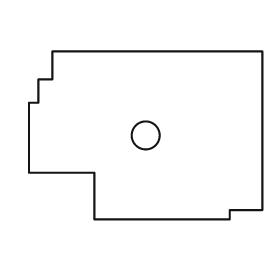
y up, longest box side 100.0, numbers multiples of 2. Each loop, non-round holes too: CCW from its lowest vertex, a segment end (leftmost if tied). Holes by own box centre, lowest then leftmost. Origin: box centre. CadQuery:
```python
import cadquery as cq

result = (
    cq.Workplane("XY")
    .moveTo(-22.0, -36.0)
    .lineTo(36.0, -36.0)
    .lineTo(36.0, -32.0)
    .lineTo(50.0, -32.0)
    .lineTo(50.0, 36.0)
    .lineTo(-40.0, 36.0)
    .lineTo(-40.0, 24.0)
    .lineTo(-46.0, 24.0)
    .lineTo(-46.0, 14.0)
    .lineTo(-50.0, 14.0)
    .lineTo(-50.0, -16.0)
    .lineTo(-22.0, -16.0)
    .close()
    .moveTo(0.0, 0.0)
    .circle(6.0)
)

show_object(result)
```